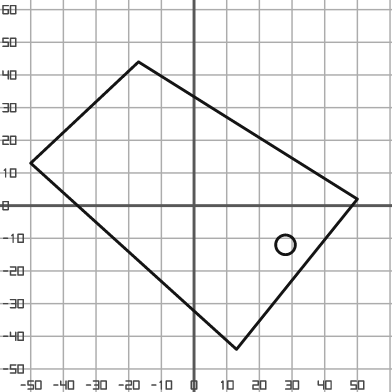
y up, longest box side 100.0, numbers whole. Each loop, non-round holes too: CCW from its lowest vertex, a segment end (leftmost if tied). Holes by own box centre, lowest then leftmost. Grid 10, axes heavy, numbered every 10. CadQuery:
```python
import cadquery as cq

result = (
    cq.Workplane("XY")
    .moveTo(13.0, -44.0)
    .lineTo(50.0, 2.0)
    .lineTo(-17.0, 44.0)
    .lineTo(-50.0, 13.0)
    .close()
    .moveTo(28.0, -12.0)
    .circle(3.0)
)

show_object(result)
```